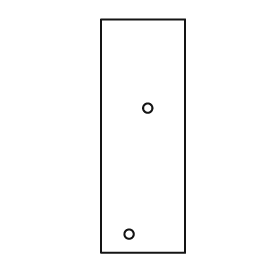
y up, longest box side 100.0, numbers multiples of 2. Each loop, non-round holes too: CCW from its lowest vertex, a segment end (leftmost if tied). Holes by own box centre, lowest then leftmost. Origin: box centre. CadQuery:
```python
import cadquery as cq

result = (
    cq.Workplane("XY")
    .moveTo(-18.0, -50.0)
    .lineTo(18.0, -50.0)
    .lineTo(18.0, 50.0)
    .lineTo(-18.0, 50.0)
    .close()
    .moveTo(-6.0, -42.0)
    .circle(2.0)
    .moveTo(2.0, 12.0)
    .circle(2.0)
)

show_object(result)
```